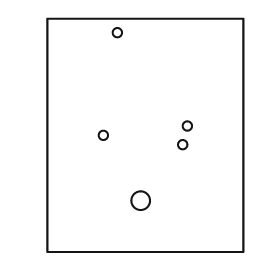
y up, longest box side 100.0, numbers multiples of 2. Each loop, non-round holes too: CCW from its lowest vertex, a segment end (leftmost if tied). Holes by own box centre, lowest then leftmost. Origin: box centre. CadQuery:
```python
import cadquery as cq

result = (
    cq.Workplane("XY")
    .moveTo(-42.0, -50.0)
    .lineTo(42.0, -50.0)
    .lineTo(42.0, 50.0)
    .lineTo(-42.0, 50.0)
    .close()
    .moveTo(-2.0, -28.0)
    .circle(4.0)
    .moveTo(16.0, -4.0)
    .circle(2.0)
    .moveTo(-18.0, 0.0)
    .circle(2.0)
    .moveTo(18.0, 4.0)
    .circle(2.0)
    .moveTo(-12.0, 44.0)
    .circle(2.0)
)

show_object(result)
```